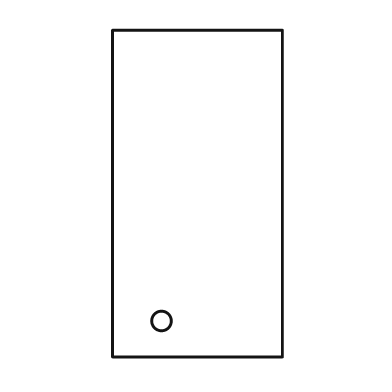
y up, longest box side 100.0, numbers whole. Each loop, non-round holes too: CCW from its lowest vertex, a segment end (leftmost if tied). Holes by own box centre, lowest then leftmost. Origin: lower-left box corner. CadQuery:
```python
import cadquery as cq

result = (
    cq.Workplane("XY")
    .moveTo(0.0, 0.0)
    .lineTo(52.0, 0.0)
    .lineTo(52.0, 100.0)
    .lineTo(0.0, 100.0)
    .close()
    .moveTo(15.0, 11.0)
    .circle(3.0)
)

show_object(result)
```